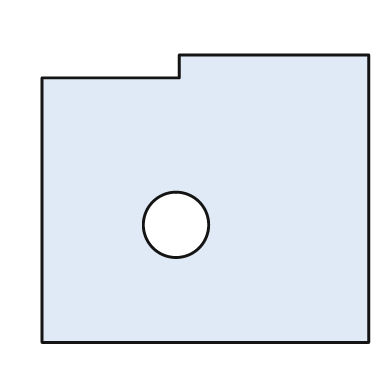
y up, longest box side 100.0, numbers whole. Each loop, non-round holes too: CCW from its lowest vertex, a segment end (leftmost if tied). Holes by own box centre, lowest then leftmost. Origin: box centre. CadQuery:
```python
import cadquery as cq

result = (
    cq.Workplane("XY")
    .moveTo(-50.0, -44.0)
    .lineTo(50.0, -44.0)
    .lineTo(50.0, 44.0)
    .lineTo(-8.0, 44.0)
    .lineTo(-8.0, 37.0)
    .lineTo(-50.0, 37.0)
    .close()
    .moveTo(-9.0, -8.0)
    .circle(10.0)
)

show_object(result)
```